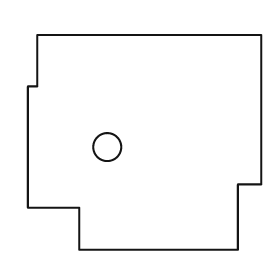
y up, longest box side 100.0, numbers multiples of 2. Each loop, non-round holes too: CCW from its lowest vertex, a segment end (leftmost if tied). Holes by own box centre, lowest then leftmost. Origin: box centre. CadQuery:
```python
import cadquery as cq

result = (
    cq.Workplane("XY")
    .moveTo(-28.0, -46.0)
    .lineTo(40.0, -46.0)
    .lineTo(40.0, -18.0)
    .lineTo(50.0, -18.0)
    .lineTo(50.0, 46.0)
    .lineTo(-46.0, 46.0)
    .lineTo(-46.0, 24.0)
    .lineTo(-50.0, 24.0)
    .lineTo(-50.0, -28.0)
    .lineTo(-28.0, -28.0)
    .close()
    .moveTo(-16.0, -2.0)
    .circle(6.0)
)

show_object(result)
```